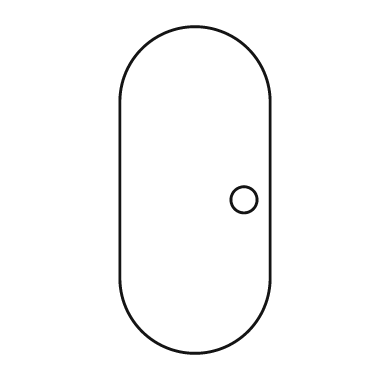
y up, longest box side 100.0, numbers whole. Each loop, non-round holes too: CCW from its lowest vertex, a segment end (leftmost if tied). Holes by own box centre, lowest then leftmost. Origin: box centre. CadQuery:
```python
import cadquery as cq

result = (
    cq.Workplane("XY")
    .moveTo(-23.0, -27.0)
    .threePointArc((0.0, -50.0), (23.0, -27.0))
    .lineTo(23.0, 27.0)
    .threePointArc((0.0, 50.0), (-23.0, 27.0))
    .close()
    .moveTo(15.0, -3.0)
    .circle(4.0)
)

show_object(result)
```